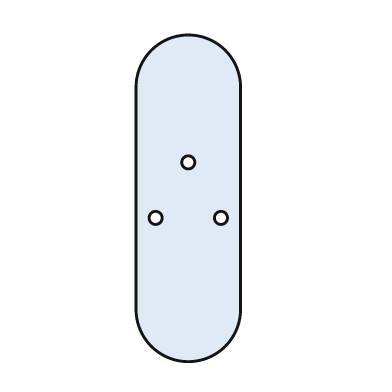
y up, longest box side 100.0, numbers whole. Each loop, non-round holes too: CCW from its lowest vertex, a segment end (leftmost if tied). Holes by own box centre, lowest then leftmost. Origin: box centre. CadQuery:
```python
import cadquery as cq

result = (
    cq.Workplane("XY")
    .moveTo(-16.0, -34.0)
    .threePointArc((0.0, -50.0), (16.0, -34.0))
    .lineTo(16.0, 34.0)
    .threePointArc((0.0, 50.0), (-16.0, 34.0))
    .close()
    .moveTo(-10.0, -6.0)
    .circle(2.0)
    .moveTo(10.0, -6.0)
    .circle(2.0)
    .moveTo(0.0, 11.0)
    .circle(2.0)
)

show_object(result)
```